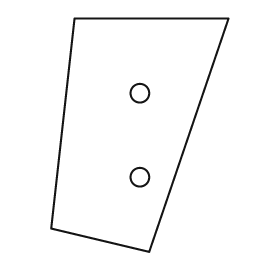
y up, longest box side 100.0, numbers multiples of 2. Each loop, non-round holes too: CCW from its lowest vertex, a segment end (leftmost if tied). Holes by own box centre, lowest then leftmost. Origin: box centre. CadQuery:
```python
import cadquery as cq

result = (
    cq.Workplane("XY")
    .moveTo(4.0, -50.0)
    .lineTo(38.0, 50.0)
    .lineTo(-28.0, 50.0)
    .lineTo(-38.0, -40.0)
    .close()
    .moveTo(0.0, -18.0)
    .circle(4.0)
    .moveTo(0.0, 18.0)
    .circle(4.0)
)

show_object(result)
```